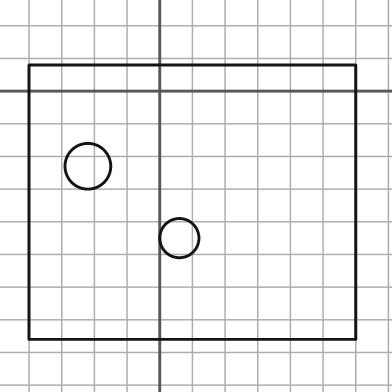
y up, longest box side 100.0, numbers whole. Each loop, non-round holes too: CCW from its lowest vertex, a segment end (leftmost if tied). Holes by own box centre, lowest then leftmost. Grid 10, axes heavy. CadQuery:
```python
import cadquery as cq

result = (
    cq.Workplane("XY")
    .moveTo(-40.0, -76.0)
    .lineTo(60.0, -76.0)
    .lineTo(60.0, 8.0)
    .lineTo(-40.0, 8.0)
    .close()
    .moveTo(6.0, -45.0)
    .circle(6.0)
    .moveTo(-22.0, -23.0)
    .circle(7.0)
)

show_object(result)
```